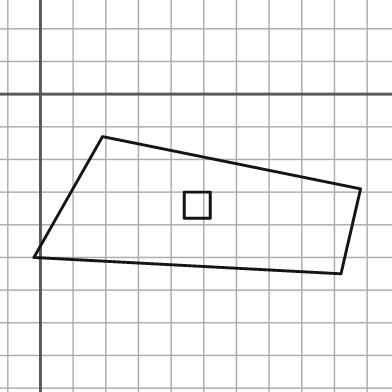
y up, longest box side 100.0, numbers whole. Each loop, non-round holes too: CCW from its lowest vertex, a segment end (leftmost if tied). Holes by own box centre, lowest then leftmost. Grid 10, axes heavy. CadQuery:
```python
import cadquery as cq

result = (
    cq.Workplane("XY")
    .moveTo(92.0, -55.0)
    .lineTo(98.0, -29.0)
    .lineTo(19.0, -13.0)
    .lineTo(-2.0, -50.0)
    .close()
    .moveTo(44.0, -38.0)
    .lineTo(52.0, -38.0)
    .lineTo(52.0, -30.0)
    .lineTo(44.0, -30.0)
    .close()
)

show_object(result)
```